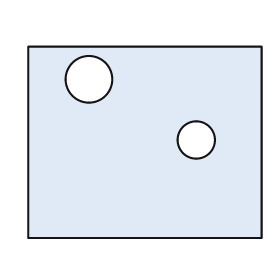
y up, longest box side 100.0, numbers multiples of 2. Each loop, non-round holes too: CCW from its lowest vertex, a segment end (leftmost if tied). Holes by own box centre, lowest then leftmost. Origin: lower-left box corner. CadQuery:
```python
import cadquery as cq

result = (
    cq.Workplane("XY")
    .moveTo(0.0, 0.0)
    .lineTo(100.0, 0.0)
    .lineTo(100.0, 82.0)
    .lineTo(0.0, 82.0)
    .close()
    .moveTo(72.0, 42.0)
    .circle(8.0)
    .moveTo(26.0, 68.0)
    .circle(10.0)
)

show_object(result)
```